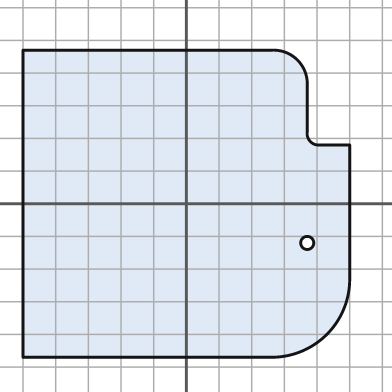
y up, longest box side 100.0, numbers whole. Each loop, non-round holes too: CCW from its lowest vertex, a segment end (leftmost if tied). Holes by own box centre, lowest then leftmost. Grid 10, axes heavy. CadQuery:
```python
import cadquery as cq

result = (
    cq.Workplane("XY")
    .moveTo(-50.0, -47.0)
    .lineTo(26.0, -47.0)
    .threePointArc((43.0, -40.0), (50.0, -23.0))
    .lineTo(50.0, 18.0)
    .lineTo(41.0, 18.0)
    .threePointArc((38.0, 19.0), (37.0, 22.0))
    .lineTo(37.0, 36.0)
    .threePointArc((34.0, 44.0), (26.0, 47.0))
    .lineTo(-50.0, 47.0)
    .close()
    .moveTo(37.0, -12.0)
    .circle(2.0)
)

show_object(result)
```